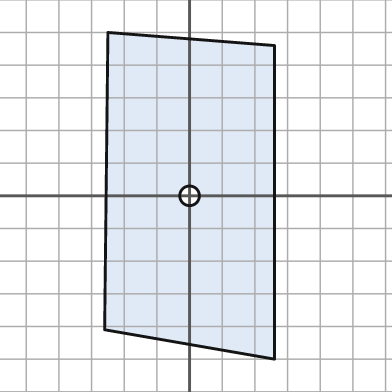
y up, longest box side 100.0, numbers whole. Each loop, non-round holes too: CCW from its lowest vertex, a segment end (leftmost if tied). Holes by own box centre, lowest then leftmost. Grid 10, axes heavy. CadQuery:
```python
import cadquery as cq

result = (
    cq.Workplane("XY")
    .moveTo(26.0, -50.0)
    .lineTo(26.0, 46.0)
    .lineTo(-25.0, 50.0)
    .lineTo(-26.0, -41.0)
    .close()
    .moveTo(0.0, 0.0)
    .circle(3.0)
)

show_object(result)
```